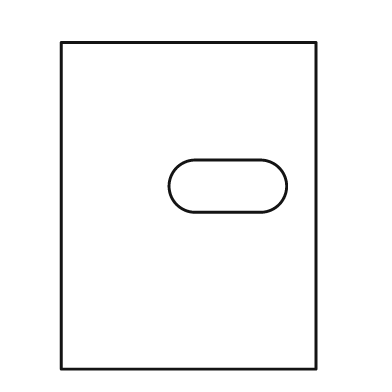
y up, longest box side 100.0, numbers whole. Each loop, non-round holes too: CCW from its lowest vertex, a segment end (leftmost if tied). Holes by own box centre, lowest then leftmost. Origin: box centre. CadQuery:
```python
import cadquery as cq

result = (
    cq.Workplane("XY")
    .moveTo(-39.0, -50.0)
    .lineTo(39.0, -50.0)
    .lineTo(39.0, 50.0)
    .lineTo(-39.0, 50.0)
    .close()
    .moveTo(2.0, -2.0)
    .lineTo(22.0, -2.0)
    .threePointArc((30.0, 6.0), (22.0, 14.0))
    .lineTo(2.0, 14.0)
    .threePointArc((-6.0, 6.0), (2.0, -2.0))
    .close()
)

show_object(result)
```